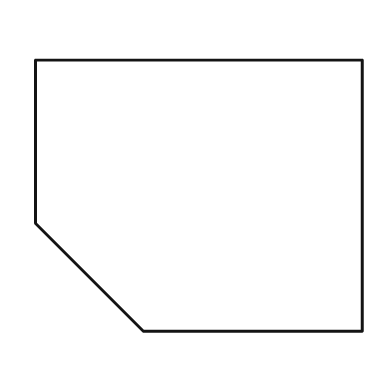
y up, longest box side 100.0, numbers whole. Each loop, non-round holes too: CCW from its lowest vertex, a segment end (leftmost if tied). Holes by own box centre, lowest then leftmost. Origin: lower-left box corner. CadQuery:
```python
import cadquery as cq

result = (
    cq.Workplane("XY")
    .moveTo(33.0, 0.0)
    .lineTo(100.0, 0.0)
    .lineTo(100.0, 83.0)
    .lineTo(0.0, 83.0)
    .lineTo(0.0, 33.0)
    .close()
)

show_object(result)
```